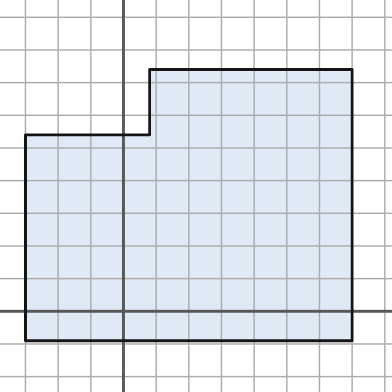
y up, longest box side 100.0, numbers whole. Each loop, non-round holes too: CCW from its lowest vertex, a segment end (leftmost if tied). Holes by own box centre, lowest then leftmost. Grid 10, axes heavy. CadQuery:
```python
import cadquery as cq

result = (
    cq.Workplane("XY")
    .moveTo(-30.0, -9.0)
    .lineTo(70.0, -9.0)
    .lineTo(70.0, 74.0)
    .lineTo(8.0, 74.0)
    .lineTo(8.0, 54.0)
    .lineTo(-30.0, 54.0)
    .close()
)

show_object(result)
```